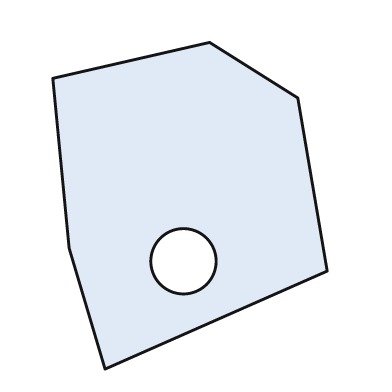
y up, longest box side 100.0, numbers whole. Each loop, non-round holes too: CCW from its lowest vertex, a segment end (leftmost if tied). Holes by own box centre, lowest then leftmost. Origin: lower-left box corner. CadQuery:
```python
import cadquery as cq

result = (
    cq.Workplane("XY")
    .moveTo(16.0, 0.0)
    .lineTo(84.0, 30.0)
    .lineTo(75.0, 83.0)
    .lineTo(48.0, 100.0)
    .lineTo(0.0, 89.0)
    .lineTo(5.0, 37.0)
    .close()
    .moveTo(40.0, 33.0)
    .circle(10.0)
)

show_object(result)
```